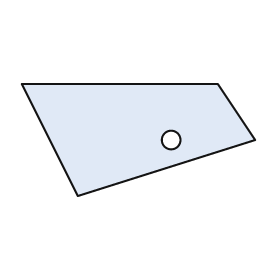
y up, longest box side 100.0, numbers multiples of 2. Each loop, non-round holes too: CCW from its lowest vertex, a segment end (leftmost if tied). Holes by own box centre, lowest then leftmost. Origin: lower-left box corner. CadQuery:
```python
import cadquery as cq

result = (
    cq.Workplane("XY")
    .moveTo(24.0, 0.0)
    .lineTo(100.0, 24.0)
    .lineTo(84.0, 48.0)
    .lineTo(0.0, 48.0)
    .close()
    .moveTo(64.0, 24.0)
    .circle(4.0)
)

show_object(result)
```